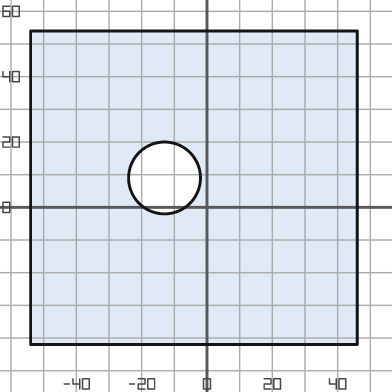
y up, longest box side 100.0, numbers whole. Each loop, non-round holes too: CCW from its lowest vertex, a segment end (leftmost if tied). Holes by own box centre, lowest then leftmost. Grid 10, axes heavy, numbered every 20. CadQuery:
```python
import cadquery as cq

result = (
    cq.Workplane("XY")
    .moveTo(-54.0, -42.0)
    .lineTo(46.0, -42.0)
    .lineTo(46.0, 54.0)
    .lineTo(-54.0, 54.0)
    .close()
    .moveTo(-13.0, 9.0)
    .circle(11.0)
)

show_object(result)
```